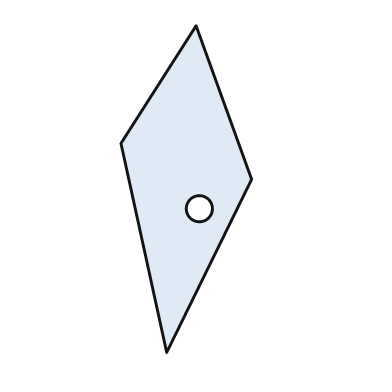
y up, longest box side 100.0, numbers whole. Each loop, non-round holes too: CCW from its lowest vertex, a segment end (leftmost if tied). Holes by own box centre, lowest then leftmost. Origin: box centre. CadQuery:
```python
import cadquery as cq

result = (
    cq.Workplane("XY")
    .moveTo(-6.0, -50.0)
    .lineTo(20.0, 3.0)
    .lineTo(3.0, 50.0)
    .lineTo(-20.0, 14.0)
    .close()
    .moveTo(4.0, -6.0)
    .circle(4.0)
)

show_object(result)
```